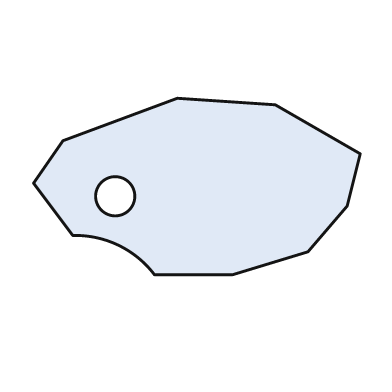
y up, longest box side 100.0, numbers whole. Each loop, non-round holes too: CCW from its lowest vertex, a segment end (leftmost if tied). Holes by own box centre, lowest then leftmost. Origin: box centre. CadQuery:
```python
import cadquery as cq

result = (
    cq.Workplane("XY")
    .moveTo(-13.0, -27.0)
    .lineTo(11.0, -27.0)
    .lineTo(34.0, -20.0)
    .lineTo(46.0, -6.0)
    .lineTo(50.0, 10.0)
    .lineTo(24.0, 25.0)
    .lineTo(-6.0, 27.0)
    .lineTo(-41.0, 14.0)
    .lineTo(-50.0, 1.0)
    .lineTo(-38.0, -15.0)
    .threePointArc((-24.0, -18.0), (-13.0, -27.0))
    .close()
    .moveTo(-25.0, -3.0)
    .circle(6.0)
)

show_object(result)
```